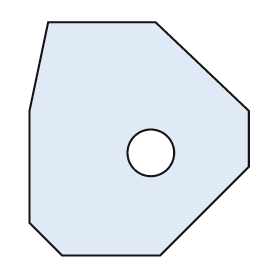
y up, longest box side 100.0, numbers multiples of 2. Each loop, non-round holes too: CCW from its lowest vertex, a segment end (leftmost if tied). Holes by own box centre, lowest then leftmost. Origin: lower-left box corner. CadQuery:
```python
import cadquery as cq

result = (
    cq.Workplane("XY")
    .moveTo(14.0, 0.0)
    .lineTo(56.0, 0.0)
    .lineTo(94.0, 38.0)
    .lineTo(94.0, 62.0)
    .lineTo(54.0, 100.0)
    .lineTo(8.0, 100.0)
    .lineTo(0.0, 62.0)
    .lineTo(0.0, 14.0)
    .close()
    .moveTo(52.0, 44.0)
    .circle(10.0)
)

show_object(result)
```